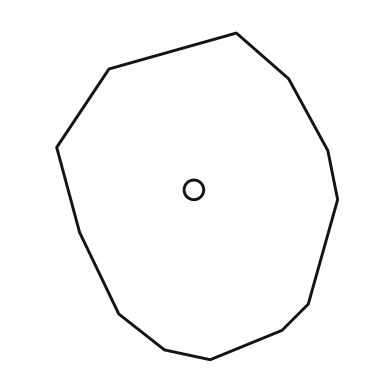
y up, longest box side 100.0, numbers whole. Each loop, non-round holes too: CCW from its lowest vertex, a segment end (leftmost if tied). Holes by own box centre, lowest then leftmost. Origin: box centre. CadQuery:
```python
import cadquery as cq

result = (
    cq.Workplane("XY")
    .moveTo(4.0, -50.0)
    .lineTo(26.0, -41.0)
    .lineTo(34.0, -33.0)
    .lineTo(43.0, -1.0)
    .lineTo(40.0, 14.0)
    .lineTo(28.0, 36.0)
    .lineTo(12.0, 50.0)
    .lineTo(-27.0, 39.0)
    .lineTo(-43.0, 15.0)
    .lineTo(-36.0, -11.0)
    .lineTo(-24.0, -36.0)
    .lineTo(-10.0, -47.0)
    .close()
    .moveTo(-1.0, 2.0)
    .circle(3.0)
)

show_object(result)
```